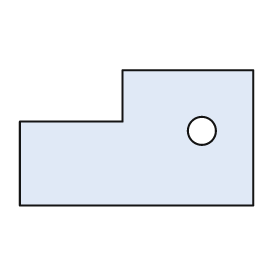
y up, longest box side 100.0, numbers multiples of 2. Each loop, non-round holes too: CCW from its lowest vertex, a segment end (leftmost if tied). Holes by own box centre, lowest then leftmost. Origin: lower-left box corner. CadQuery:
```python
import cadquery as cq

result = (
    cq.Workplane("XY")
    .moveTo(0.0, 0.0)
    .lineTo(100.0, 0.0)
    .lineTo(100.0, 58.0)
    .lineTo(44.0, 58.0)
    .lineTo(44.0, 36.0)
    .lineTo(0.0, 36.0)
    .close()
    .moveTo(78.0, 32.0)
    .circle(6.0)
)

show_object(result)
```